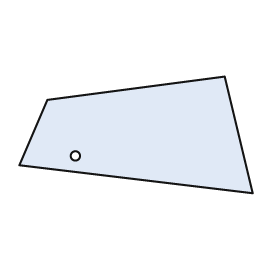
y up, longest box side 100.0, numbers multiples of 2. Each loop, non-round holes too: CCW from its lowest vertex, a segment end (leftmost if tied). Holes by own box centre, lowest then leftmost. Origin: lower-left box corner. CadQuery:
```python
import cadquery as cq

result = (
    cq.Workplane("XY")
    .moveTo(100.0, 0.0)
    .lineTo(88.0, 50.0)
    .lineTo(12.0, 40.0)
    .lineTo(0.0, 12.0)
    .close()
    .moveTo(24.0, 16.0)
    .circle(2.0)
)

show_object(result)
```